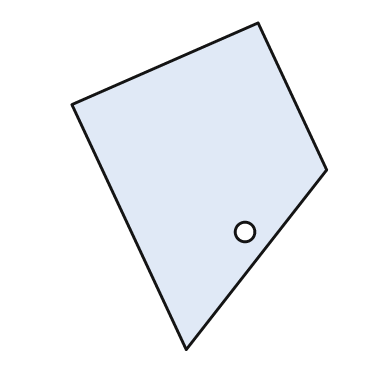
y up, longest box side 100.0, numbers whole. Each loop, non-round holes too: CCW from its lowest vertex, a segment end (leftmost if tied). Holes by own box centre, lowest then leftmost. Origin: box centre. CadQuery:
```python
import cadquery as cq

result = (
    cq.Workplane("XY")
    .moveTo(-4.0, -50.0)
    .lineTo(39.0, 5.0)
    .lineTo(18.0, 50.0)
    .lineTo(-39.0, 25.0)
    .close()
    .moveTo(14.0, -14.0)
    .circle(3.0)
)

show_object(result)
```